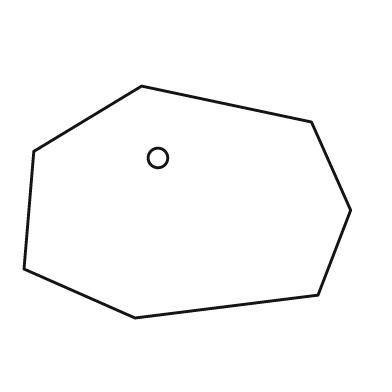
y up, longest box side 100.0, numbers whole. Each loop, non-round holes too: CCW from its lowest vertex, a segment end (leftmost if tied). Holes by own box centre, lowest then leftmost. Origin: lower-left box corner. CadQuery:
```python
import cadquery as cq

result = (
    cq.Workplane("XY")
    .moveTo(34.0, 0.0)
    .lineTo(90.0, 7.0)
    .lineTo(100.0, 33.0)
    .lineTo(88.0, 60.0)
    .lineTo(36.0, 71.0)
    .lineTo(3.0, 51.0)
    .lineTo(0.0, 15.0)
    .close()
    .moveTo(41.0, 49.0)
    .circle(3.0)
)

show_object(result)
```